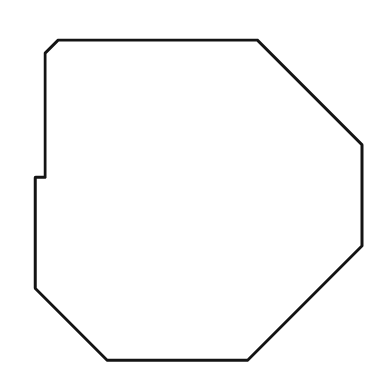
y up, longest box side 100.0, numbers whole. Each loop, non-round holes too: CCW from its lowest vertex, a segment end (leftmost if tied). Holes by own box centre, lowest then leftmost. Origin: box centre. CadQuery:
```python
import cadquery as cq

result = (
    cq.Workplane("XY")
    .moveTo(-28.0, -49.0)
    .lineTo(15.0, -49.0)
    .lineTo(50.0, -14.0)
    .lineTo(50.0, 17.0)
    .lineTo(18.0, 49.0)
    .lineTo(-43.0, 49.0)
    .lineTo(-47.0, 45.0)
    .lineTo(-47.0, 7.0)
    .lineTo(-50.0, 7.0)
    .lineTo(-50.0, -27.0)
    .close()
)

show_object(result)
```